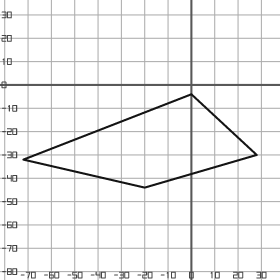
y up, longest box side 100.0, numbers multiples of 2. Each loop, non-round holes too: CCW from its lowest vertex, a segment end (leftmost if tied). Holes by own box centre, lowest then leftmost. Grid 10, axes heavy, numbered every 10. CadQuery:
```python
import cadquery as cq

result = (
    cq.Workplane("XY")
    .moveTo(-20.0, -44.0)
    .lineTo(28.0, -30.0)
    .lineTo(0.0, -4.0)
    .lineTo(-72.0, -32.0)
    .close()
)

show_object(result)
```